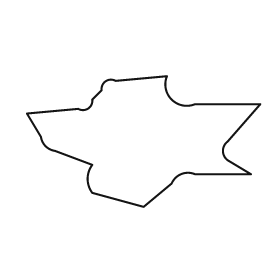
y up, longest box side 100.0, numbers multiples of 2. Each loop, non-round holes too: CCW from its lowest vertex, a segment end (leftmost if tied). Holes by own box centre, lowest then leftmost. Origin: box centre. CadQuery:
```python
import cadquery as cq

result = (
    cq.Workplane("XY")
    .moveTo(0.0, -28.0)
    .lineTo(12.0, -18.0)
    .threePointArc((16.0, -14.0), (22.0, -14.0))
    .lineTo(46.0, -14.0)
    .lineTo(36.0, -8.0)
    .threePointArc((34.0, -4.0), (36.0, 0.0))
    .lineTo(50.0, 16.0)
    .lineTo(22.0, 16.0)
    .threePointArc((12.0, 18.0), (10.0, 28.0))
    .lineTo(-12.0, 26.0)
    .threePointArc((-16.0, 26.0), (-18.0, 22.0))
    .lineTo(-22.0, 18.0)
    .threePointArc((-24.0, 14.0), (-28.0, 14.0))
    .lineTo(-50.0, 12.0)
    .lineTo(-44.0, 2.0)
    .threePointArc((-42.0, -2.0), (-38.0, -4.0))
    .lineTo(-22.0, -10.0)
    .threePointArc((-24.0, -16.0), (-22.0, -22.0))
    .close()
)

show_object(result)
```